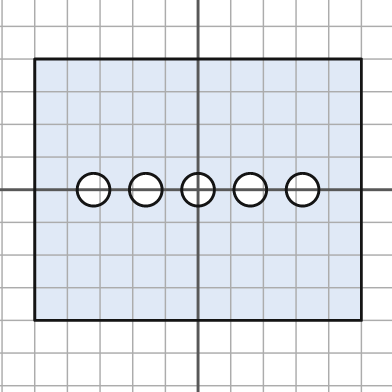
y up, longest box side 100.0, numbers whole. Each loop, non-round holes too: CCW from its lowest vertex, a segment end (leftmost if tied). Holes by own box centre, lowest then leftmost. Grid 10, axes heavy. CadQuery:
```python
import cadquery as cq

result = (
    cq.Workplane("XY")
    .moveTo(-50.0, -40.0)
    .lineTo(50.0, -40.0)
    .lineTo(50.0, 40.0)
    .lineTo(-50.0, 40.0)
    .close()
    .moveTo(-32.0, 0.0)
    .circle(5.0)
    .moveTo(-16.0, 0.0)
    .circle(5.0)
    .moveTo(0.0, 0.0)
    .circle(5.0)
    .moveTo(16.0, 0.0)
    .circle(5.0)
    .moveTo(32.0, 0.0)
    .circle(5.0)
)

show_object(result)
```